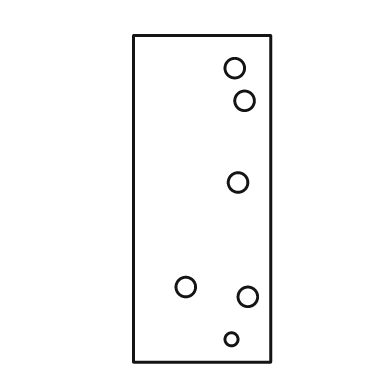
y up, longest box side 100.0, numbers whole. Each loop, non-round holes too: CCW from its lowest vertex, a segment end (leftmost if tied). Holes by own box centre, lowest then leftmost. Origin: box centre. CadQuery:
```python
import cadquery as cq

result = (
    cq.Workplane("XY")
    .moveTo(-21.0, -50.0)
    .lineTo(21.0, -50.0)
    .lineTo(21.0, 50.0)
    .lineTo(-21.0, 50.0)
    .close()
    .moveTo(9.0, -43.0)
    .circle(2.0)
    .moveTo(14.0, -30.0)
    .circle(3.0)
    .moveTo(-5.0, -27.0)
    .circle(3.0)
    .moveTo(11.0, 5.0)
    .circle(3.0)
    .moveTo(13.0, 30.0)
    .circle(3.0)
    .moveTo(10.0, 40.0)
    .circle(3.0)
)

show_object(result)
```